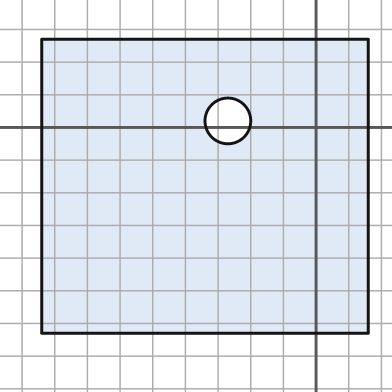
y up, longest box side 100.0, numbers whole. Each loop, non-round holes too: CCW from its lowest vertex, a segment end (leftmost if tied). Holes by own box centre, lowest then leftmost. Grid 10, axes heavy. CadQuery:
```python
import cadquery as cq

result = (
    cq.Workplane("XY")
    .moveTo(-84.0, -63.0)
    .lineTo(16.0, -63.0)
    .lineTo(16.0, 27.0)
    .lineTo(-84.0, 27.0)
    .close()
    .moveTo(-27.0, 2.0)
    .circle(7.0)
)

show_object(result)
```